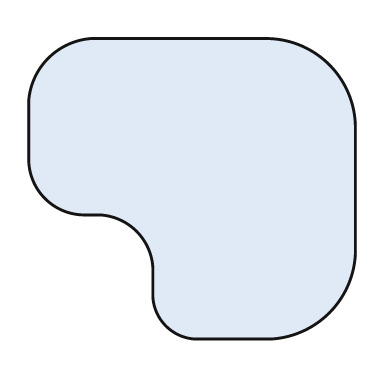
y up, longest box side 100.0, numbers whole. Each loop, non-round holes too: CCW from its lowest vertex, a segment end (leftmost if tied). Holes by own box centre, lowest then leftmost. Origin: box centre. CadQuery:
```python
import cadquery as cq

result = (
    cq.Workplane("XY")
    .moveTo(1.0, -46.0)
    .lineTo(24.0, -46.0)
    .threePointArc((42.0, -38.0), (50.0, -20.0))
    .lineTo(50.0, 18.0)
    .threePointArc((42.0, 38.0), (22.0, 46.0))
    .lineTo(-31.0, 46.0)
    .threePointArc((-44.0, 40.0), (-50.0, 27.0))
    .lineTo(-50.0, 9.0)
    .threePointArc((-45.0, -3.0), (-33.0, -8.0))
    .lineTo(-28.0, -8.0)
    .threePointArc((-17.0, -13.0), (-12.0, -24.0))
    .lineTo(-12.0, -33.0)
    .threePointArc((-8.0, -42.0), (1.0, -46.0))
    .close()
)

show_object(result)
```